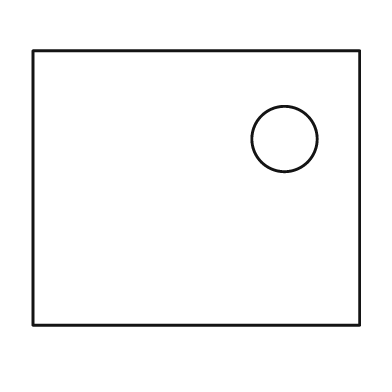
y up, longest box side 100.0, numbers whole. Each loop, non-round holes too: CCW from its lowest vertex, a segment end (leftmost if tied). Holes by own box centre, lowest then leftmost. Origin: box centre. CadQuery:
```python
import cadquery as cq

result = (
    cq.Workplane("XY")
    .moveTo(-50.0, -42.0)
    .lineTo(50.0, -42.0)
    .lineTo(50.0, 42.0)
    .lineTo(-50.0, 42.0)
    .close()
    .moveTo(27.0, 15.0)
    .circle(10.0)
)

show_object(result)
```